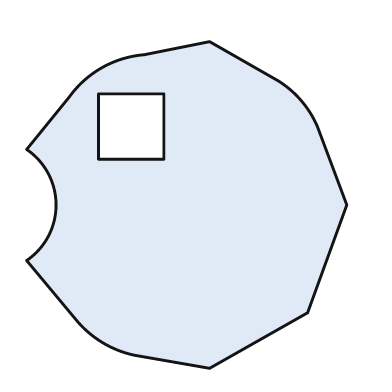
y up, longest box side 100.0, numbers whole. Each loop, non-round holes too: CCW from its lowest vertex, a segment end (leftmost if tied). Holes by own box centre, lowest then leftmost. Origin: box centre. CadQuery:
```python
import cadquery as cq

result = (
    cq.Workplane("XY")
    .moveTo(7.0, -50.0)
    .lineTo(37.0, -33.0)
    .lineTo(49.0, 0.0)
    .lineTo(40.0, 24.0)
    .threePointArc((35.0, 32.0), (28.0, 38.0))
    .lineTo(7.0, 50.0)
    .lineTo(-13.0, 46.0)
    .threePointArc((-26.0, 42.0), (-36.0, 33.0))
    .lineTo(-49.0, 17.0)
    .threePointArc((-40.0, 0.0), (-49.0, -17.0))
    .lineTo(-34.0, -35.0)
    .threePointArc((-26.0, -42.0), (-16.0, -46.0))
    .close()
    .moveTo(-27.0, 14.0)
    .lineTo(-7.0, 14.0)
    .lineTo(-7.0, 34.0)
    .lineTo(-27.0, 34.0)
    .close()
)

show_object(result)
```